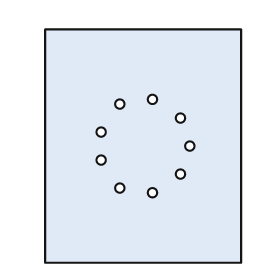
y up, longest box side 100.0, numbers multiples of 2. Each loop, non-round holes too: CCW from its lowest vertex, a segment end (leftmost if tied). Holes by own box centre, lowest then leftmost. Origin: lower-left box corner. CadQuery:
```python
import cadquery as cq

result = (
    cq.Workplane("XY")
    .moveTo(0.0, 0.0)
    .lineTo(84.0, 0.0)
    .lineTo(84.0, 100.0)
    .lineTo(0.0, 100.0)
    .close()
    .moveTo(46.0, 30.0)
    .circle(2.0)
    .moveTo(32.0, 32.0)
    .circle(2.0)
    .moveTo(58.0, 38.0)
    .circle(2.0)
    .moveTo(24.0, 44.0)
    .circle(2.0)
    .moveTo(62.0, 50.0)
    .circle(2.0)
    .moveTo(24.0, 56.0)
    .circle(2.0)
    .moveTo(58.0, 62.0)
    .circle(2.0)
    .moveTo(32.0, 68.0)
    .circle(2.0)
    .moveTo(46.0, 70.0)
    .circle(2.0)
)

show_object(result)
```